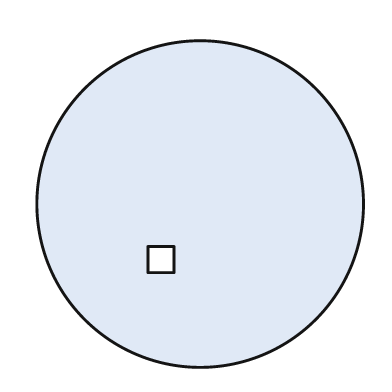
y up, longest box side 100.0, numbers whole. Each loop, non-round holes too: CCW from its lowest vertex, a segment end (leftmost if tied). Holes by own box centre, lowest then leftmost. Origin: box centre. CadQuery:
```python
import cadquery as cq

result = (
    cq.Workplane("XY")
    .moveTo(0.0, 0.0)
    .circle(50.0)
    .moveTo(-16.0, -21.0)
    .lineTo(-8.0, -21.0)
    .lineTo(-8.0, -13.0)
    .lineTo(-16.0, -13.0)
    .close()
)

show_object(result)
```